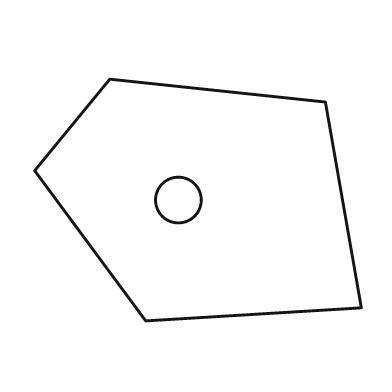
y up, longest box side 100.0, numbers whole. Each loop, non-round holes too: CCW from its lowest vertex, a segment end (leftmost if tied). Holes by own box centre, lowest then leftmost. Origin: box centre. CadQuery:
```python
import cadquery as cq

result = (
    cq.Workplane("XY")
    .moveTo(-16.0, -37.0)
    .lineTo(50.0, -33.0)
    .lineTo(39.0, 30.0)
    .lineTo(-27.0, 37.0)
    .lineTo(-50.0, 9.0)
    .close()
    .moveTo(-6.0, 0.0)
    .circle(7.0)
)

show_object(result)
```